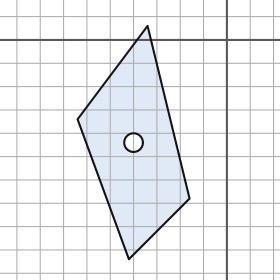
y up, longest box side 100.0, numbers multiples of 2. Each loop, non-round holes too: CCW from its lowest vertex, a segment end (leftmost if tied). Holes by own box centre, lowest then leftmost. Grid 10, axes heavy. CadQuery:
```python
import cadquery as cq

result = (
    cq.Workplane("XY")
    .moveTo(-42.0, -94.0)
    .lineTo(-16.0, -68.0)
    .lineTo(-34.0, 6.0)
    .lineTo(-64.0, -34.0)
    .close()
    .moveTo(-40.0, -44.0)
    .circle(4.0)
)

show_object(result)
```